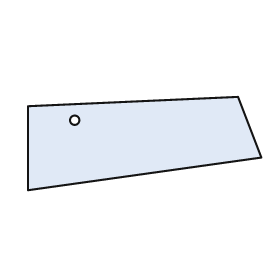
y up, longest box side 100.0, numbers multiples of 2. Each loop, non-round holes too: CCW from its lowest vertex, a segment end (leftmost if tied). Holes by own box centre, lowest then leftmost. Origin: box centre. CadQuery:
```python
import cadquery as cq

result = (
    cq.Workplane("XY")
    .moveTo(-50.0, -20.0)
    .lineTo(50.0, -6.0)
    .lineTo(40.0, 20.0)
    .lineTo(-50.0, 16.0)
    .close()
    .moveTo(-30.0, 10.0)
    .circle(2.0)
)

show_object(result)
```